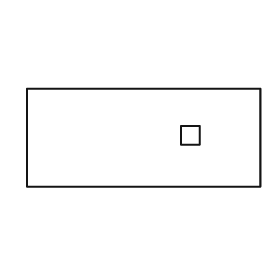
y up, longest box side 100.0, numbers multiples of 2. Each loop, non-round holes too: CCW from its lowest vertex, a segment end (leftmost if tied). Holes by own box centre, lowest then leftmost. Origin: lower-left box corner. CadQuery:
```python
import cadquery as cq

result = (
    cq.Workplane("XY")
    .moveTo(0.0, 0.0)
    .lineTo(100.0, 0.0)
    .lineTo(100.0, 42.0)
    .lineTo(0.0, 42.0)
    .close()
    .moveTo(66.0, 18.0)
    .lineTo(74.0, 18.0)
    .lineTo(74.0, 26.0)
    .lineTo(66.0, 26.0)
    .close()
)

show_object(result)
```